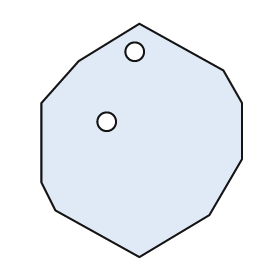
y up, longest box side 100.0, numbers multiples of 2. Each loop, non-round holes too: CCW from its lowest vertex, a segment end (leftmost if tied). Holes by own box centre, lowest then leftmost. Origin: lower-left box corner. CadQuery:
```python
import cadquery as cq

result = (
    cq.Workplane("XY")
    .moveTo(42.0, 0.0)
    .lineTo(72.0, 18.0)
    .lineTo(86.0, 42.0)
    .lineTo(86.0, 66.0)
    .lineTo(78.0, 80.0)
    .lineTo(42.0, 100.0)
    .lineTo(16.0, 84.0)
    .lineTo(0.0, 66.0)
    .lineTo(0.0, 32.0)
    .lineTo(6.0, 20.0)
    .close()
    .moveTo(28.0, 58.0)
    .circle(4.0)
    .moveTo(40.0, 88.0)
    .circle(4.0)
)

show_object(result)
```